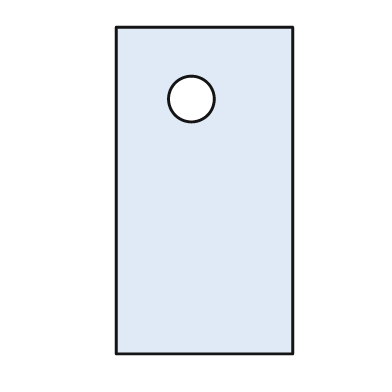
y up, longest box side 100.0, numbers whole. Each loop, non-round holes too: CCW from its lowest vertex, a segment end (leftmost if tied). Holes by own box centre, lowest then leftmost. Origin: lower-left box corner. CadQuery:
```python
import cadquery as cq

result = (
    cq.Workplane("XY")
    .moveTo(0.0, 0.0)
    .lineTo(54.0, 0.0)
    .lineTo(54.0, 100.0)
    .lineTo(0.0, 100.0)
    .close()
    .moveTo(23.0, 78.0)
    .circle(7.0)
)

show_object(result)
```